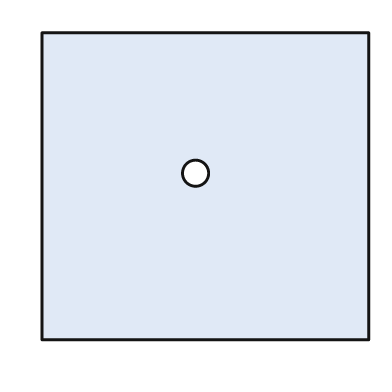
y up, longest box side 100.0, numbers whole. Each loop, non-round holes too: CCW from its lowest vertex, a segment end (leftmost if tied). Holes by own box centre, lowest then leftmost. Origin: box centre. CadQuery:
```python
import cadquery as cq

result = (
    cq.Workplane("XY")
    .moveTo(-50.0, -47.0)
    .lineTo(50.0, -47.0)
    .lineTo(50.0, 47.0)
    .lineTo(-50.0, 47.0)
    .close()
    .moveTo(-3.0, 4.0)
    .circle(4.0)
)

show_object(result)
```